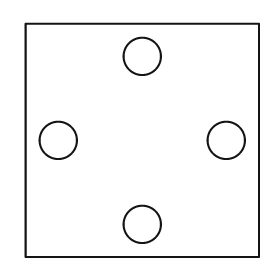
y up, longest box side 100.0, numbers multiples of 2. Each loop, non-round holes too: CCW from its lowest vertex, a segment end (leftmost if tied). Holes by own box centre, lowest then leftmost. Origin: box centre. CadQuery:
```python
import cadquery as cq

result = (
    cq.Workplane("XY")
    .moveTo(-50.0, -50.0)
    .lineTo(50.0, -50.0)
    .lineTo(50.0, 50.0)
    .lineTo(-50.0, 50.0)
    .close()
    .moveTo(0.0, -36.0)
    .circle(8.0)
    .moveTo(-36.0, 0.0)
    .circle(8.0)
    .moveTo(36.0, 0.0)
    .circle(8.0)
    .moveTo(0.0, 36.0)
    .circle(8.0)
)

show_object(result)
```